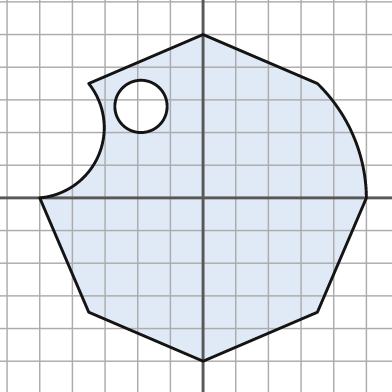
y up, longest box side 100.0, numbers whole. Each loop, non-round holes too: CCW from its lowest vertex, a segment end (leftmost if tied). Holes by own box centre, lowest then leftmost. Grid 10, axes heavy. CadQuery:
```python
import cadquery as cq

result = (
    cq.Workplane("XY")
    .moveTo(0.0, -50.0)
    .lineTo(35.0, -35.0)
    .lineTo(50.0, 0.0)
    .threePointArc((46.0, 19.0), (35.0, 35.0))
    .lineTo(0.0, 50.0)
    .lineTo(-35.0, 35.0)
    .threePointArc((-32.0, 13.0), (-50.0, 0.0))
    .lineTo(-35.0, -35.0)
    .close()
    .moveTo(-19.0, 28.0)
    .circle(8.0)
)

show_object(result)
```